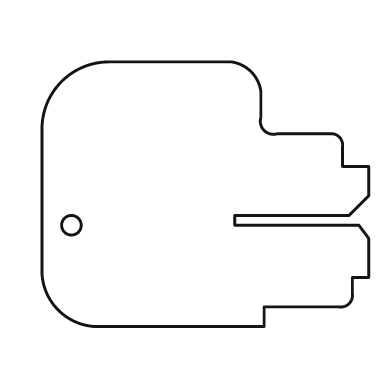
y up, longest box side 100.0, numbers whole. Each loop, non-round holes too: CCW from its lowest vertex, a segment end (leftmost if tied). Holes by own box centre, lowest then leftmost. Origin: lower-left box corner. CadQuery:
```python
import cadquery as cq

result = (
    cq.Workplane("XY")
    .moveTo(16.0, 0.0)
    .lineTo(68.0, 0.0)
    .lineTo(68.0, 6.0)
    .lineTo(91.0, 6.0)
    .threePointArc((94.0, 7.0), (95.0, 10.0))
    .lineTo(95.0, 15.0)
    .lineTo(100.0, 15.0)
    .lineTo(100.0, 27.0)
    .lineTo(97.0, 31.0)
    .lineTo(59.0, 31.0)
    .lineTo(59.0, 34.0)
    .lineTo(94.0, 34.0)
    .lineTo(100.0, 40.0)
    .lineTo(100.0, 49.0)
    .lineTo(92.0, 49.0)
    .lineTo(92.0, 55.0)
    .threePointArc((91.0, 58.0), (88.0, 59.0))
    .lineTo(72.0, 59.0)
    .threePointArc((68.0, 60.0), (67.0, 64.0))
    .lineTo(67.0, 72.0)
    .threePointArc((64.0, 78.0), (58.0, 81.0))
    .lineTo(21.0, 81.0)
    .threePointArc((6.0, 75.0), (0.0, 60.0))
    .lineTo(0.0, 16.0)
    .threePointArc((5.0, 5.0), (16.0, 0.0))
    .close()
    .moveTo(9.0, 31.0)
    .circle(3.0)
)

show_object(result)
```